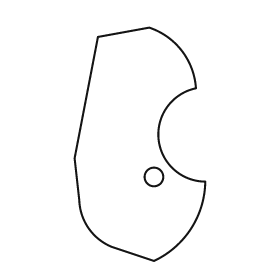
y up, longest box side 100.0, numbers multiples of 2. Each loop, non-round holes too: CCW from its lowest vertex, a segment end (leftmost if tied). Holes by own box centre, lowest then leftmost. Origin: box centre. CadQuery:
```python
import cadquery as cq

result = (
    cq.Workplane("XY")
    .moveTo(6.0, -50.0)
    .threePointArc((22.0, -36.0), (28.0, -16.0))
    .threePointArc((8.0, 2.0), (24.0, 24.0))
    .threePointArc((18.0, 40.0), (4.0, 50.0))
    .lineTo(-18.0, 46.0)
    .lineTo(-28.0, -6.0)
    .lineTo(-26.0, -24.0)
    .threePointArc((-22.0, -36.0), (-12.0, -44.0))
    .close()
    .moveTo(6.0, -14.0)
    .circle(4.0)
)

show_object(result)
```